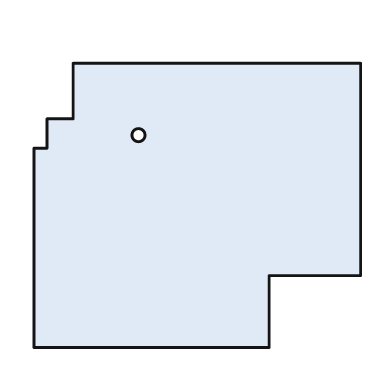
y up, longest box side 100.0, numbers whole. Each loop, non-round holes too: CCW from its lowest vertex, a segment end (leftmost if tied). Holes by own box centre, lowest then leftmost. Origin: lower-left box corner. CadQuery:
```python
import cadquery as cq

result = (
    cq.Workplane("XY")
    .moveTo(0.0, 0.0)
    .lineTo(72.0, 0.0)
    .lineTo(72.0, 22.0)
    .lineTo(100.0, 22.0)
    .lineTo(100.0, 87.0)
    .lineTo(12.0, 87.0)
    .lineTo(12.0, 70.0)
    .lineTo(4.0, 70.0)
    .lineTo(4.0, 61.0)
    .lineTo(0.0, 61.0)
    .close()
    .moveTo(32.0, 65.0)
    .circle(2.0)
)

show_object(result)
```